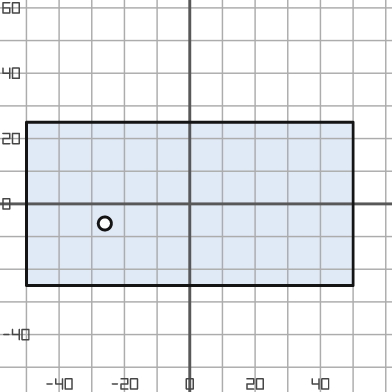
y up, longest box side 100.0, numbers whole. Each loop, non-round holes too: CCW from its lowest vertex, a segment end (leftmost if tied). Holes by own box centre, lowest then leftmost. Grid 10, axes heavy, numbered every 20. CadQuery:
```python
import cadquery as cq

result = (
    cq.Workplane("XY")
    .moveTo(-50.0, -25.0)
    .lineTo(50.0, -25.0)
    .lineTo(50.0, 25.0)
    .lineTo(-50.0, 25.0)
    .close()
    .moveTo(-26.0, -6.0)
    .circle(2.0)
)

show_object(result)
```